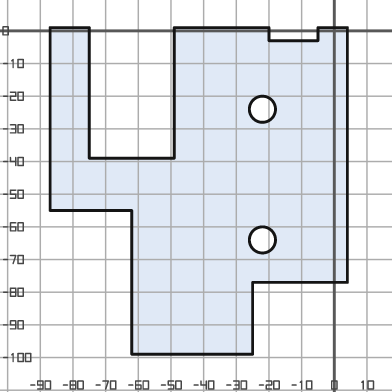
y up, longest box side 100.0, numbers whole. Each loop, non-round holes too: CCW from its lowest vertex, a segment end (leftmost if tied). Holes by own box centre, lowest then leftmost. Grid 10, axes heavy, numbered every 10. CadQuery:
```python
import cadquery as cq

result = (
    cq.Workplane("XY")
    .moveTo(-62.0, -99.0)
    .lineTo(-25.0, -99.0)
    .lineTo(-25.0, -77.0)
    .lineTo(4.0, -77.0)
    .lineTo(4.0, 1.0)
    .lineTo(-5.0, 1.0)
    .lineTo(-5.0, -3.0)
    .lineTo(-20.0, -3.0)
    .lineTo(-20.0, 1.0)
    .lineTo(-49.0, 1.0)
    .lineTo(-49.0, -39.0)
    .lineTo(-75.0, -39.0)
    .lineTo(-75.0, 1.0)
    .lineTo(-87.0, 1.0)
    .lineTo(-87.0, -55.0)
    .lineTo(-62.0, -55.0)
    .close()
    .moveTo(-22.0, -64.0)
    .circle(4.0)
    .moveTo(-22.0, -24.0)
    .circle(4.0)
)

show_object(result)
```